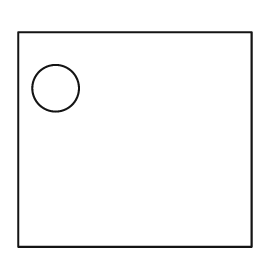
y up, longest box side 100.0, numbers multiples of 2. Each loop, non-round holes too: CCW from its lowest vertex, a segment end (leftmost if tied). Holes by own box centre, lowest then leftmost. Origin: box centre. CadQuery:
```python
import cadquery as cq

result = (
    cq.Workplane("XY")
    .moveTo(-50.0, -46.0)
    .lineTo(50.0, -46.0)
    .lineTo(50.0, 46.0)
    .lineTo(-50.0, 46.0)
    .close()
    .moveTo(-34.0, 22.0)
    .circle(10.0)
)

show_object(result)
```